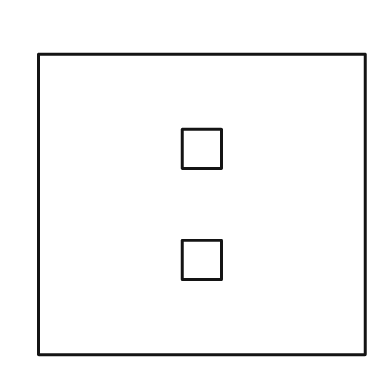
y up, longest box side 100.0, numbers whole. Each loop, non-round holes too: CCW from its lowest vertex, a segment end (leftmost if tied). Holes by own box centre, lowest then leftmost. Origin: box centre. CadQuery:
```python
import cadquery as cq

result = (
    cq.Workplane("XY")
    .moveTo(-50.0, -46.0)
    .lineTo(50.0, -46.0)
    .lineTo(50.0, 46.0)
    .lineTo(-50.0, 46.0)
    .close()
    .moveTo(-6.0, -23.0)
    .lineTo(6.0, -23.0)
    .lineTo(6.0, -11.0)
    .lineTo(-6.0, -11.0)
    .close()
    .moveTo(-6.0, 11.0)
    .lineTo(6.0, 11.0)
    .lineTo(6.0, 23.0)
    .lineTo(-6.0, 23.0)
    .close()
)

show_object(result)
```